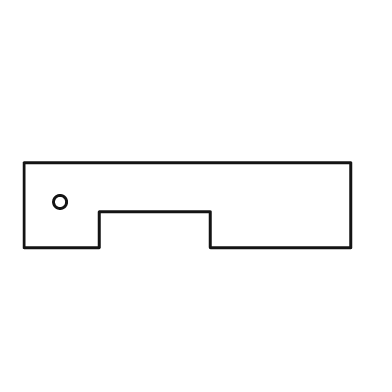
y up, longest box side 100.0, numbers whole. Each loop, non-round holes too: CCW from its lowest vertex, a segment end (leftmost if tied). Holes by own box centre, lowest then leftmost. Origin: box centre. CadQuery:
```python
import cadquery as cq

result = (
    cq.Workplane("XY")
    .moveTo(-50.0, -13.0)
    .lineTo(-27.0, -13.0)
    .lineTo(-27.0, -2.0)
    .lineTo(7.0, -2.0)
    .lineTo(7.0, -13.0)
    .lineTo(50.0, -13.0)
    .lineTo(50.0, 13.0)
    .lineTo(-50.0, 13.0)
    .close()
    .moveTo(-39.0, 1.0)
    .circle(2.0)
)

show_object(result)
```